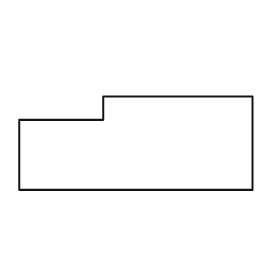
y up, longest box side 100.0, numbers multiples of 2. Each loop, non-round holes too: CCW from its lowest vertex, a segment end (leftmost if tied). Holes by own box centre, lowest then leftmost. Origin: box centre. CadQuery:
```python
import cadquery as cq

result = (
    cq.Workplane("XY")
    .moveTo(-50.0, -20.0)
    .lineTo(50.0, -20.0)
    .lineTo(50.0, 20.0)
    .lineTo(-14.0, 20.0)
    .lineTo(-14.0, 10.0)
    .lineTo(-50.0, 10.0)
    .close()
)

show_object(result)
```